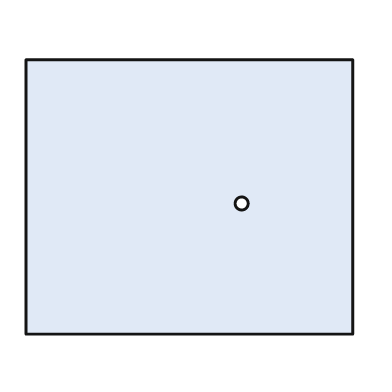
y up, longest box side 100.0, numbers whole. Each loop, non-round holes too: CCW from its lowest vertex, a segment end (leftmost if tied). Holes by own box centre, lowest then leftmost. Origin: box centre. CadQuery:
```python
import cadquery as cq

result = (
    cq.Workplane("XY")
    .moveTo(-50.0, -42.0)
    .lineTo(50.0, -42.0)
    .lineTo(50.0, 42.0)
    .lineTo(-50.0, 42.0)
    .close()
    .moveTo(16.0, -2.0)
    .circle(2.0)
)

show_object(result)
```